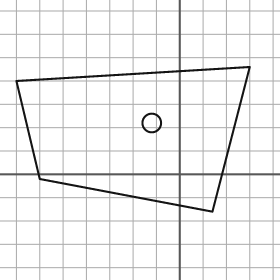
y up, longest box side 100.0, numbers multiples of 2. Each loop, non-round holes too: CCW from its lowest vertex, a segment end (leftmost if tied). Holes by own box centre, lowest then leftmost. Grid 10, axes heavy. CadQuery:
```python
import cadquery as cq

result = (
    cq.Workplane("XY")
    .moveTo(14.0, -16.0)
    .lineTo(30.0, 46.0)
    .lineTo(-70.0, 40.0)
    .lineTo(-60.0, -2.0)
    .close()
    .moveTo(-12.0, 22.0)
    .circle(4.0)
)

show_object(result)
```